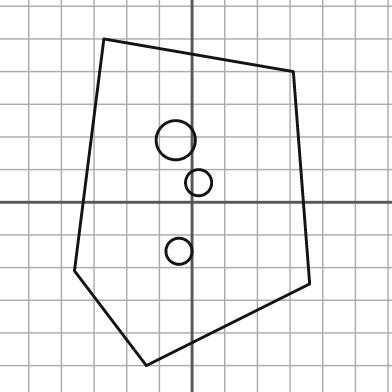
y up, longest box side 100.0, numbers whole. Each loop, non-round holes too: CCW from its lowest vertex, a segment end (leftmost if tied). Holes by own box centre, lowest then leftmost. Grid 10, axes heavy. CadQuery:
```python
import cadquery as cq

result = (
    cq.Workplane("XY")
    .moveTo(-14.0, -50.0)
    .lineTo(36.0, -25.0)
    .lineTo(31.0, 40.0)
    .lineTo(-27.0, 50.0)
    .lineTo(-36.0, -21.0)
    .close()
    .moveTo(-4.0, -15.0)
    .circle(4.0)
    .moveTo(2.0, 6.0)
    .circle(4.0)
    .moveTo(-5.0, 19.0)
    .circle(6.0)
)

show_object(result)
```